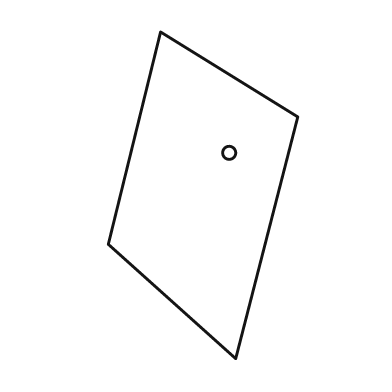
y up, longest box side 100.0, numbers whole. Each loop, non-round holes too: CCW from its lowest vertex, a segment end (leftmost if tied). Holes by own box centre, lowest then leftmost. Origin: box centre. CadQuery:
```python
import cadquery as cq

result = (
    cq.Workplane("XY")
    .moveTo(10.0, -50.0)
    .lineTo(29.0, 24.0)
    .lineTo(-13.0, 50.0)
    .lineTo(-29.0, -15.0)
    .close()
    .moveTo(8.0, 13.0)
    .circle(2.0)
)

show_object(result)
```